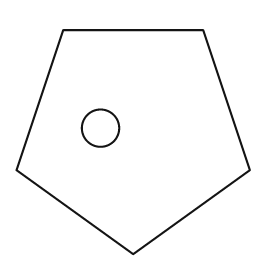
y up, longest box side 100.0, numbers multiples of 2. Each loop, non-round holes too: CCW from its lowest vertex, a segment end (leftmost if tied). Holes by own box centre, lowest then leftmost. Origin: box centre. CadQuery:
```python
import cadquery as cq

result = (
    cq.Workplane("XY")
    .moveTo(0.0, -48.0)
    .lineTo(50.0, -12.0)
    .lineTo(30.0, 48.0)
    .lineTo(-30.0, 48.0)
    .lineTo(-50.0, -12.0)
    .close()
    .moveTo(-14.0, 6.0)
    .circle(8.0)
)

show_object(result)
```